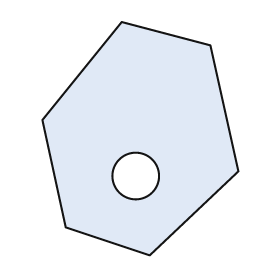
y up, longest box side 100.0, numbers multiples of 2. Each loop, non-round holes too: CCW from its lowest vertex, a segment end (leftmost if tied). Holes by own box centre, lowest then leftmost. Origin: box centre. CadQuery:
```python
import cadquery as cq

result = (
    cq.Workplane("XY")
    .moveTo(4.0, -50.0)
    .lineTo(42.0, -14.0)
    .lineTo(30.0, 40.0)
    .lineTo(-8.0, 50.0)
    .lineTo(-42.0, 8.0)
    .lineTo(-32.0, -38.0)
    .close()
    .moveTo(-2.0, -16.0)
    .circle(10.0)
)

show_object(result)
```